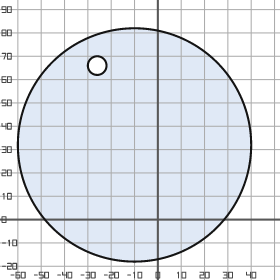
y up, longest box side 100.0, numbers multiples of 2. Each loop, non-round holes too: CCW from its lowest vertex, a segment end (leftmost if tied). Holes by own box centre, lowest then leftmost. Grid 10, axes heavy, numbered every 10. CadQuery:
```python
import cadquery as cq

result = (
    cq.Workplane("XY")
    .moveTo(-10.0, 32.0)
    .circle(50.0)
    .moveTo(-26.0, 66.0)
    .circle(4.0)
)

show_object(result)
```